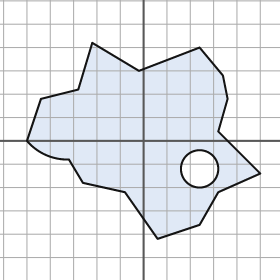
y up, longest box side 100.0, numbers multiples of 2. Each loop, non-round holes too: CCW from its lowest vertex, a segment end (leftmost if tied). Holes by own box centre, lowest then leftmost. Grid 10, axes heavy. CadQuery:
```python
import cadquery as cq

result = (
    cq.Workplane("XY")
    .moveTo(6.0, -42.0)
    .lineTo(24.0, -36.0)
    .lineTo(32.0, -22.0)
    .lineTo(50.0, -14.0)
    .lineTo(32.0, 4.0)
    .lineTo(36.0, 18.0)
    .lineTo(34.0, 28.0)
    .lineTo(24.0, 40.0)
    .lineTo(-2.0, 30.0)
    .lineTo(-22.0, 42.0)
    .lineTo(-28.0, 22.0)
    .lineTo(-44.0, 18.0)
    .lineTo(-50.0, 0.0)
    .threePointArc((-42.0, -6.0), (-32.0, -8.0))
    .lineTo(-26.0, -18.0)
    .lineTo(-8.0, -22.0)
    .close()
    .moveTo(24.0, -12.0)
    .circle(8.0)
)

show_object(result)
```